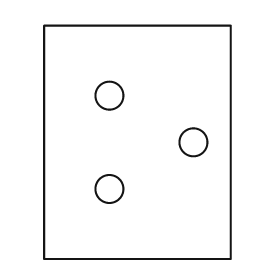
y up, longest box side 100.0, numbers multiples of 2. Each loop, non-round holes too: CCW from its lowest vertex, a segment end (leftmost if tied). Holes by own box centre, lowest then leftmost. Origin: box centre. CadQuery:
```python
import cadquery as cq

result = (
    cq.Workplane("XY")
    .moveTo(-40.0, -50.0)
    .lineTo(40.0, -50.0)
    .lineTo(40.0, 50.0)
    .lineTo(-40.0, 50.0)
    .close()
    .moveTo(-12.0, -20.0)
    .circle(6.0)
    .moveTo(24.0, 0.0)
    .circle(6.0)
    .moveTo(-12.0, 20.0)
    .circle(6.0)
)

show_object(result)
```